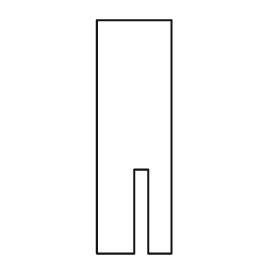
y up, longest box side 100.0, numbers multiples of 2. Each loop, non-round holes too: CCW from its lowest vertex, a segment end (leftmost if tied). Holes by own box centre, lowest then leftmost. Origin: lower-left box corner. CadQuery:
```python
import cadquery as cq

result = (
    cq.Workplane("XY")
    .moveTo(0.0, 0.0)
    .lineTo(16.0, 0.0)
    .lineTo(16.0, 36.0)
    .lineTo(22.0, 36.0)
    .lineTo(22.0, 0.0)
    .lineTo(32.0, 0.0)
    .lineTo(32.0, 100.0)
    .lineTo(0.0, 100.0)
    .close()
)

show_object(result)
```